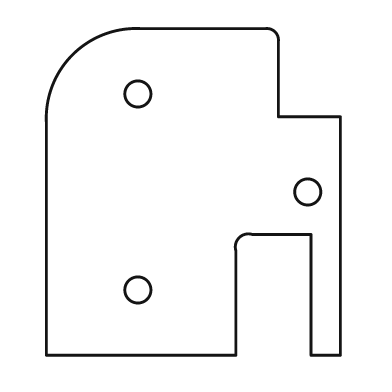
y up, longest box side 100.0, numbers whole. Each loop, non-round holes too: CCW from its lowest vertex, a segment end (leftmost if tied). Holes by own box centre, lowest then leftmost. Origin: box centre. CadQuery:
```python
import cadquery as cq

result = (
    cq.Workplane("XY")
    .moveTo(-45.0, -50.0)
    .lineTo(13.0, -50.0)
    .lineTo(13.0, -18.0)
    .threePointArc((14.0, -14.0), (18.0, -13.0))
    .lineTo(36.0, -13.0)
    .lineTo(36.0, -50.0)
    .lineTo(45.0, -50.0)
    .lineTo(45.0, 23.0)
    .lineTo(26.0, 23.0)
    .lineTo(26.0, 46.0)
    .threePointArc((25.0, 49.0), (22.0, 50.0))
    .lineTo(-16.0, 50.0)
    .threePointArc((-37.0, 42.0), (-45.0, 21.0))
    .close()
    .moveTo(-17.0, -30.0)
    .circle(4.0)
    .moveTo(35.0, 0.0)
    .circle(4.0)
    .moveTo(-17.0, 30.0)
    .circle(4.0)
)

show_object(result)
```